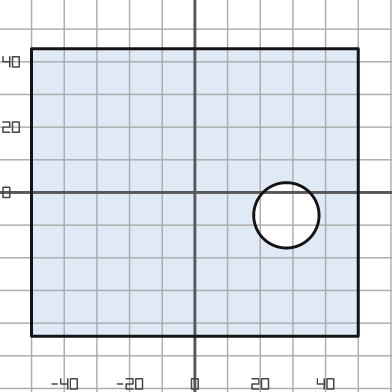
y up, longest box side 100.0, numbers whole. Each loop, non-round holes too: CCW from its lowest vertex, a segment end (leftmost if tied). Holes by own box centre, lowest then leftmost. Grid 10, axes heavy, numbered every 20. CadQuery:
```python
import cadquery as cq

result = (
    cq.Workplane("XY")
    .moveTo(-50.0, -44.0)
    .lineTo(50.0, -44.0)
    .lineTo(50.0, 44.0)
    .lineTo(-50.0, 44.0)
    .close()
    .moveTo(28.0, -7.0)
    .circle(10.0)
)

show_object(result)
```